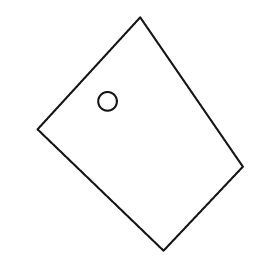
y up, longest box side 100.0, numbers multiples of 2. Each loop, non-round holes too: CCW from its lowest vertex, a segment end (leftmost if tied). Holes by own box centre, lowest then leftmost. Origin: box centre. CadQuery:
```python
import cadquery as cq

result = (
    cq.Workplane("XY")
    .moveTo(10.0, -50.0)
    .lineTo(44.0, -14.0)
    .lineTo(0.0, 50.0)
    .lineTo(-44.0, 2.0)
    .close()
    .moveTo(-14.0, 14.0)
    .circle(4.0)
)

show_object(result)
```